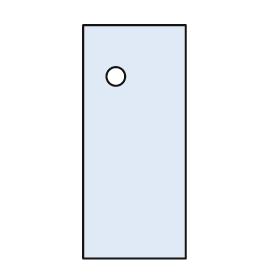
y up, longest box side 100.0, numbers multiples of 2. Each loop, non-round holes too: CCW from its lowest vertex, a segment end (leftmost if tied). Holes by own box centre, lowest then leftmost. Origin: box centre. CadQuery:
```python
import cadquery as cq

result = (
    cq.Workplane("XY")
    .moveTo(-22.0, -50.0)
    .lineTo(22.0, -50.0)
    .lineTo(22.0, 50.0)
    .lineTo(-22.0, 50.0)
    .close()
    .moveTo(-8.0, 28.0)
    .circle(4.0)
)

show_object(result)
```